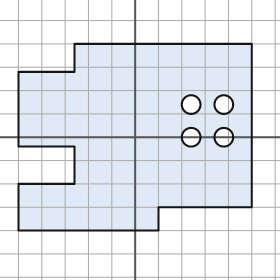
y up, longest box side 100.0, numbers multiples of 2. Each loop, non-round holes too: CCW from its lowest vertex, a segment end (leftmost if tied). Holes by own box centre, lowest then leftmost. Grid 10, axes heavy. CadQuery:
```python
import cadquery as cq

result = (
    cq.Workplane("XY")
    .moveTo(-50.0, -40.0)
    .lineTo(10.0, -40.0)
    .lineTo(10.0, -30.0)
    .lineTo(50.0, -30.0)
    .lineTo(50.0, 40.0)
    .lineTo(-26.0, 40.0)
    .lineTo(-26.0, 28.0)
    .lineTo(-50.0, 28.0)
    .lineTo(-50.0, -4.0)
    .lineTo(-26.0, -4.0)
    .lineTo(-26.0, -20.0)
    .lineTo(-50.0, -20.0)
    .close()
    .moveTo(24.0, 0.0)
    .circle(4.0)
    .moveTo(38.0, 0.0)
    .circle(4.0)
    .moveTo(24.0, 14.0)
    .circle(4.0)
    .moveTo(38.0, 14.0)
    .circle(4.0)
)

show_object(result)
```